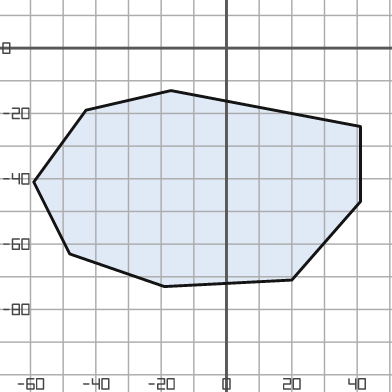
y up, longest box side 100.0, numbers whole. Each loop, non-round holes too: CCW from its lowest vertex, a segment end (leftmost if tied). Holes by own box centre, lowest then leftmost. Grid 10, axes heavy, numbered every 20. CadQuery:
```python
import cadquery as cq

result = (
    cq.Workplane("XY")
    .moveTo(-19.0, -73.0)
    .lineTo(20.0, -71.0)
    .lineTo(41.0, -47.0)
    .lineTo(41.0, -24.0)
    .lineTo(-17.0, -13.0)
    .lineTo(-43.0, -19.0)
    .lineTo(-59.0, -41.0)
    .lineTo(-48.0, -63.0)
    .close()
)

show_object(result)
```